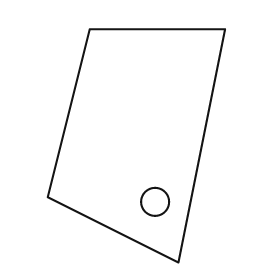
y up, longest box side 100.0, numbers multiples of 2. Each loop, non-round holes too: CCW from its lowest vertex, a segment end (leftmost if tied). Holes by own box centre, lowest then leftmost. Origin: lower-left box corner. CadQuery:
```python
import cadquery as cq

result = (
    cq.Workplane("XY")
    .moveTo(56.0, 0.0)
    .lineTo(76.0, 100.0)
    .lineTo(18.0, 100.0)
    .lineTo(0.0, 28.0)
    .close()
    .moveTo(46.0, 26.0)
    .circle(6.0)
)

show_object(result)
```